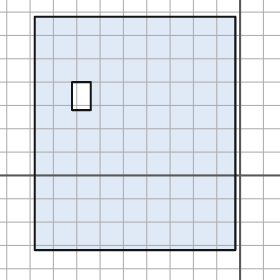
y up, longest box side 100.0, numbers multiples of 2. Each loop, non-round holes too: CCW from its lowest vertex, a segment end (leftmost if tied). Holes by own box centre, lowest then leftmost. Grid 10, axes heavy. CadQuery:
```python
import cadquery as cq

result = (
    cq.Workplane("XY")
    .moveTo(-88.0, -32.0)
    .lineTo(-2.0, -32.0)
    .lineTo(-2.0, 68.0)
    .lineTo(-88.0, 68.0)
    .close()
    .moveTo(-72.0, 28.0)
    .lineTo(-64.0, 28.0)
    .lineTo(-64.0, 40.0)
    .lineTo(-72.0, 40.0)
    .close()
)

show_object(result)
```